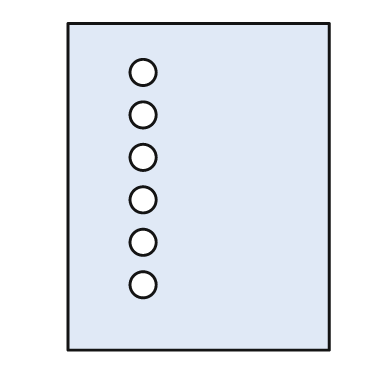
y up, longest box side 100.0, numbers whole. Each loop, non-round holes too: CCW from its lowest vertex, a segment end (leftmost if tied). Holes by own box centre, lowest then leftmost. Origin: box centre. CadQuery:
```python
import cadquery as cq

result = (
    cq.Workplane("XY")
    .moveTo(-40.0, -50.0)
    .lineTo(40.0, -50.0)
    .lineTo(40.0, 50.0)
    .lineTo(-40.0, 50.0)
    .close()
    .moveTo(-17.0, -30.0)
    .circle(4.0)
    .moveTo(-17.0, -17.0)
    .circle(4.0)
    .moveTo(-17.0, -4.0)
    .circle(4.0)
    .moveTo(-17.0, 9.0)
    .circle(4.0)
    .moveTo(-17.0, 22.0)
    .circle(4.0)
    .moveTo(-17.0, 35.0)
    .circle(4.0)
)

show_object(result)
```